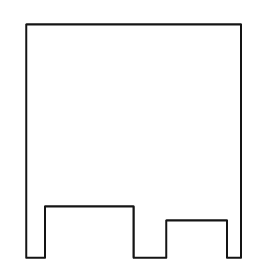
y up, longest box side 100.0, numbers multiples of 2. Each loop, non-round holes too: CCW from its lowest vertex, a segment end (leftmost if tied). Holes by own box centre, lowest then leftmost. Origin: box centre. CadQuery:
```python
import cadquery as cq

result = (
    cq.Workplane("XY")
    .moveTo(-46.0, -50.0)
    .lineTo(-38.0, -50.0)
    .lineTo(-38.0, -28.0)
    .lineTo(0.0, -28.0)
    .lineTo(0.0, -50.0)
    .lineTo(14.0, -50.0)
    .lineTo(14.0, -34.0)
    .lineTo(40.0, -34.0)
    .lineTo(40.0, -50.0)
    .lineTo(46.0, -50.0)
    .lineTo(46.0, 50.0)
    .lineTo(-46.0, 50.0)
    .close()
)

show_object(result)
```